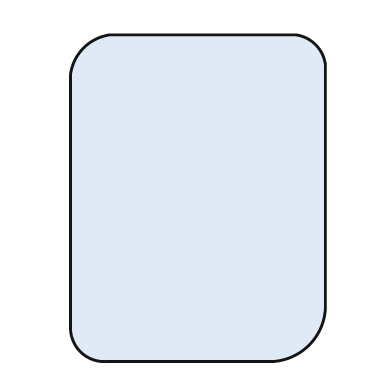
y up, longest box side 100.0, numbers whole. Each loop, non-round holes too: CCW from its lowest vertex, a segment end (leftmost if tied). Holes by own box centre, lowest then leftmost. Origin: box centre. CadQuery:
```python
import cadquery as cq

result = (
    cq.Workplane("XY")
    .moveTo(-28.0, -50.0)
    .lineTo(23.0, -50.0)
    .threePointArc((34.0, -45.0), (39.0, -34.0))
    .lineTo(39.0, 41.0)
    .threePointArc((36.0, 47.0), (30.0, 50.0))
    .lineTo(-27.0, 50.0)
    .threePointArc((-35.0, 46.0), (-39.0, 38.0))
    .lineTo(-39.0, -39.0)
    .threePointArc((-36.0, -47.0), (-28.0, -50.0))
    .close()
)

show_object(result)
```